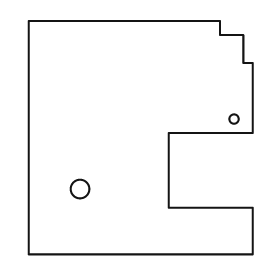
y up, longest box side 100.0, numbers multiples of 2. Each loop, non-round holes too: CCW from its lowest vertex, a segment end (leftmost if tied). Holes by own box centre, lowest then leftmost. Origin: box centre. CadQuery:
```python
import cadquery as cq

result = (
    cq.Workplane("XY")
    .moveTo(-48.0, -50.0)
    .lineTo(48.0, -50.0)
    .lineTo(48.0, -30.0)
    .lineTo(12.0, -30.0)
    .lineTo(12.0, 2.0)
    .lineTo(48.0, 2.0)
    .lineTo(48.0, 32.0)
    .lineTo(44.0, 32.0)
    .lineTo(44.0, 44.0)
    .lineTo(34.0, 44.0)
    .lineTo(34.0, 50.0)
    .lineTo(-48.0, 50.0)
    .close()
    .moveTo(-26.0, -22.0)
    .circle(4.0)
    .moveTo(40.0, 8.0)
    .circle(2.0)
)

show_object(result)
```